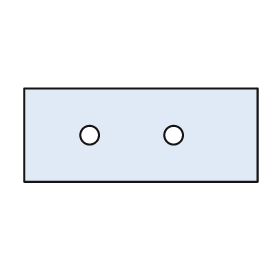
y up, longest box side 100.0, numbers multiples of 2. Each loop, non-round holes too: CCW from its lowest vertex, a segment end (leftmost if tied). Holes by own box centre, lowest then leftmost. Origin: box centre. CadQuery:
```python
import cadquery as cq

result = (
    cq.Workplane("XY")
    .moveTo(-50.0, -20.0)
    .lineTo(50.0, -20.0)
    .lineTo(50.0, 20.0)
    .lineTo(-50.0, 20.0)
    .close()
    .moveTo(-22.0, 0.0)
    .circle(4.0)
    .moveTo(14.0, 0.0)
    .circle(4.0)
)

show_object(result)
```